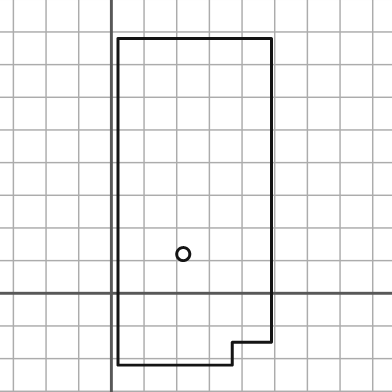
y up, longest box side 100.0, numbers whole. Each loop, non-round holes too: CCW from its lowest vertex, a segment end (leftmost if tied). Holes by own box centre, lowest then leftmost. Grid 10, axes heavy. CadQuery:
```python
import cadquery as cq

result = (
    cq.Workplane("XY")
    .moveTo(2.0, -22.0)
    .lineTo(37.0, -22.0)
    .lineTo(37.0, -15.0)
    .lineTo(49.0, -15.0)
    .lineTo(49.0, 78.0)
    .lineTo(2.0, 78.0)
    .close()
    .moveTo(22.0, 12.0)
    .circle(2.0)
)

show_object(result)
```